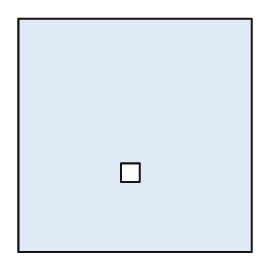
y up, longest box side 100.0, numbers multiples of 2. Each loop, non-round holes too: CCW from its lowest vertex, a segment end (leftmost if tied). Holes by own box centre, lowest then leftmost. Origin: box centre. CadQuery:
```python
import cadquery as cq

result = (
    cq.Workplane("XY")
    .moveTo(-50.0, -50.0)
    .lineTo(50.0, -50.0)
    .lineTo(50.0, 50.0)
    .lineTo(-50.0, 50.0)
    .close()
    .moveTo(-6.0, -20.0)
    .lineTo(2.0, -20.0)
    .lineTo(2.0, -12.0)
    .lineTo(-6.0, -12.0)
    .close()
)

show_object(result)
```